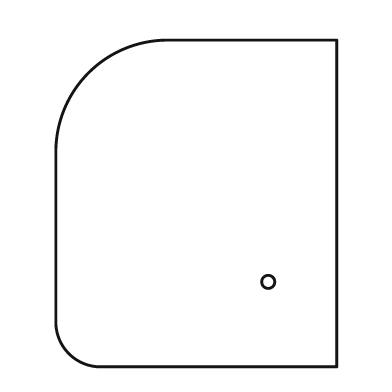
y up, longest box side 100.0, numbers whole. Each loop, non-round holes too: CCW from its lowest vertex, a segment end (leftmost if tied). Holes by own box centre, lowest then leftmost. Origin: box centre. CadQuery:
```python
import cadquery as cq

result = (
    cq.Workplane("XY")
    .moveTo(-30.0, -50.0)
    .lineTo(43.0, -50.0)
    .lineTo(43.0, 50.0)
    .lineTo(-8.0, 50.0)
    .threePointArc((-33.0, 40.0), (-43.0, 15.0))
    .lineTo(-43.0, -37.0)
    .threePointArc((-39.0, -46.0), (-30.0, -50.0))
    .close()
    .moveTo(22.0, -24.0)
    .circle(2.0)
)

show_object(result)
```